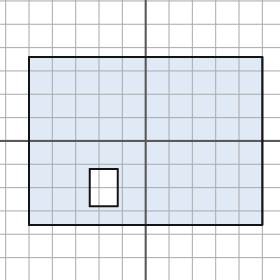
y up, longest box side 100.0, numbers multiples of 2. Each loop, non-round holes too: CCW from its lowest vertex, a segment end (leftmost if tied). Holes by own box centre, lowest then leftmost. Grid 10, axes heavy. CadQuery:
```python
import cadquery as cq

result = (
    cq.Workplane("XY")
    .moveTo(-50.0, -36.0)
    .lineTo(50.0, -36.0)
    .lineTo(50.0, 36.0)
    .lineTo(-50.0, 36.0)
    .close()
    .moveTo(-24.0, -28.0)
    .lineTo(-12.0, -28.0)
    .lineTo(-12.0, -12.0)
    .lineTo(-24.0, -12.0)
    .close()
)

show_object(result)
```